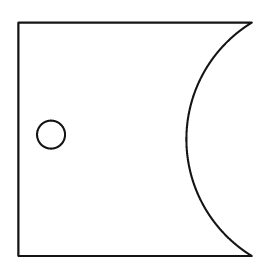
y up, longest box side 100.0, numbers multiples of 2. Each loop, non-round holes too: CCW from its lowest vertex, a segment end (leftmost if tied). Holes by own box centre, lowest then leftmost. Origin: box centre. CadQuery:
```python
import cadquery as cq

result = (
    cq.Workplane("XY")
    .moveTo(-50.0, -50.0)
    .lineTo(50.0, -50.0)
    .threePointArc((22.0, 0.0), (50.0, 50.0))
    .lineTo(-50.0, 50.0)
    .close()
    .moveTo(-36.0, 2.0)
    .circle(6.0)
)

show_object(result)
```